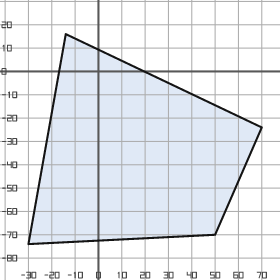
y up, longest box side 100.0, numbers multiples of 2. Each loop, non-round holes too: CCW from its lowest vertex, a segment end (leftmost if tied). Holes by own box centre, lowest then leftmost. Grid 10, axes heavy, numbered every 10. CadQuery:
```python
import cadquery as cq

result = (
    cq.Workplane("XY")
    .moveTo(-30.0, -74.0)
    .lineTo(50.0, -70.0)
    .lineTo(70.0, -24.0)
    .lineTo(-14.0, 16.0)
    .close()
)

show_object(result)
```